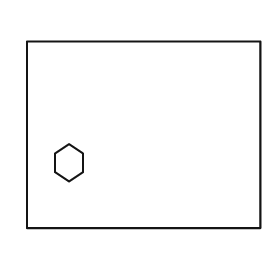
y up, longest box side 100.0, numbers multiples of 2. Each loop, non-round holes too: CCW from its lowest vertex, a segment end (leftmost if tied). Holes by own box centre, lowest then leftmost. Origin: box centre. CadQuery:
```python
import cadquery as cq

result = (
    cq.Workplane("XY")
    .moveTo(-50.0, -40.0)
    .lineTo(50.0, -40.0)
    .lineTo(50.0, 40.0)
    .lineTo(-50.0, 40.0)
    .close()
    .moveTo(-32.0, -20.0)
    .lineTo(-26.0, -16.0)
    .lineTo(-26.0, -8.0)
    .lineTo(-32.0, -4.0)
    .lineTo(-38.0, -8.0)
    .lineTo(-38.0, -16.0)
    .close()
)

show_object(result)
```